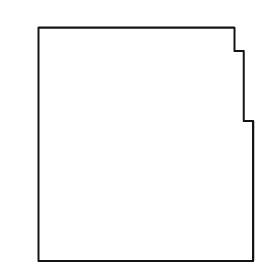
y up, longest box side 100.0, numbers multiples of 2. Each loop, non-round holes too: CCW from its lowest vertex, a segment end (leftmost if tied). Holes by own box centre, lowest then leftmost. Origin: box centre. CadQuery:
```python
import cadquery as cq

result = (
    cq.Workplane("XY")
    .moveTo(-46.0, -50.0)
    .lineTo(46.0, -50.0)
    .lineTo(46.0, 10.0)
    .lineTo(42.0, 10.0)
    .lineTo(42.0, 40.0)
    .lineTo(38.0, 40.0)
    .lineTo(38.0, 50.0)
    .lineTo(-46.0, 50.0)
    .close()
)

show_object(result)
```